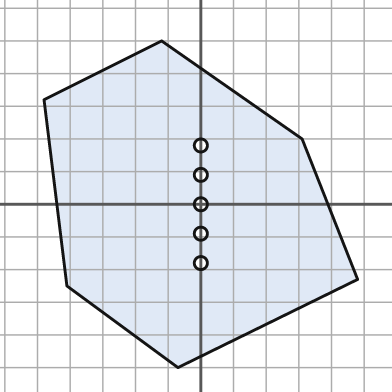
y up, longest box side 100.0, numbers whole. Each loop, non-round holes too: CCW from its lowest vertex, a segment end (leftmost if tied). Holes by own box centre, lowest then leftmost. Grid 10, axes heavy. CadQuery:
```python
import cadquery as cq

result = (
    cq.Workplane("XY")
    .moveTo(-7.0, -50.0)
    .lineTo(48.0, -23.0)
    .lineTo(31.0, 20.0)
    .lineTo(-12.0, 50.0)
    .lineTo(-48.0, 32.0)
    .lineTo(-41.0, -25.0)
    .close()
    .moveTo(0.0, -18.0)
    .circle(2.0)
    .moveTo(0.0, -9.0)
    .circle(2.0)
    .moveTo(0.0, 0.0)
    .circle(2.0)
    .moveTo(0.0, 9.0)
    .circle(2.0)
    .moveTo(0.0, 18.0)
    .circle(2.0)
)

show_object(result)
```